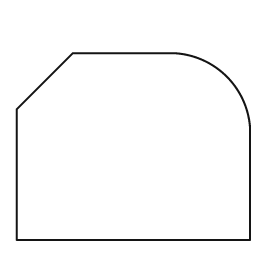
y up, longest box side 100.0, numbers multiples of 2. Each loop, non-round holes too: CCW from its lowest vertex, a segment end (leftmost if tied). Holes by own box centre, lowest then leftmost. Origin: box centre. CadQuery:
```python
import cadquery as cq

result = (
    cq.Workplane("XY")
    .moveTo(-50.0, -40.0)
    .lineTo(50.0, -40.0)
    .lineTo(50.0, 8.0)
    .threePointArc((40.0, 30.0), (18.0, 40.0))
    .lineTo(-26.0, 40.0)
    .lineTo(-50.0, 16.0)
    .close()
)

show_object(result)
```